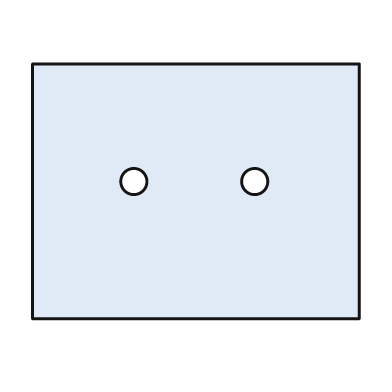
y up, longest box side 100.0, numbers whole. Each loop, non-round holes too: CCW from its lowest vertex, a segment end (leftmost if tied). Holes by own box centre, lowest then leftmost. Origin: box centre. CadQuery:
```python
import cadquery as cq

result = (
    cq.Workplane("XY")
    .moveTo(-50.0, -39.0)
    .lineTo(50.0, -39.0)
    .lineTo(50.0, 39.0)
    .lineTo(-50.0, 39.0)
    .close()
    .moveTo(-19.0, 3.0)
    .circle(4.0)
    .moveTo(18.0, 3.0)
    .circle(4.0)
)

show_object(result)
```